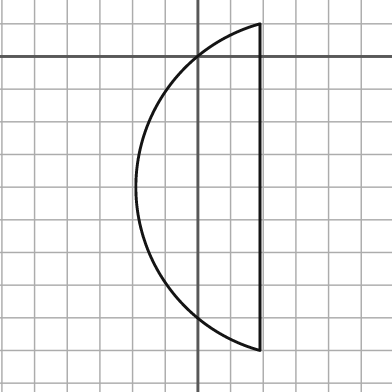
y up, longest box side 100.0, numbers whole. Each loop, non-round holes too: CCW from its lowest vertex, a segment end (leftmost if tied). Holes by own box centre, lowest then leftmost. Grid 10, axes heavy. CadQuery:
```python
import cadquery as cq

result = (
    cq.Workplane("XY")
    .moveTo(19.0, -90.0)
    .lineTo(19.0, 10.0)
    .threePointArc((-19.0, -40.0), (19.0, -90.0))
    .close()
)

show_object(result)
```